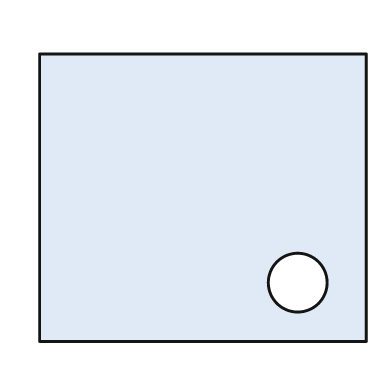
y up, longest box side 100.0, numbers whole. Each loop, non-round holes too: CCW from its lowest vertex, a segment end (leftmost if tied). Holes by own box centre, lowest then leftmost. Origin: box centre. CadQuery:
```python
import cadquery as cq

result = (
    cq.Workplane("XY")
    .moveTo(-50.0, -44.0)
    .lineTo(50.0, -44.0)
    .lineTo(50.0, 44.0)
    .lineTo(-50.0, 44.0)
    .close()
    .moveTo(29.0, -26.0)
    .circle(9.0)
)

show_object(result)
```